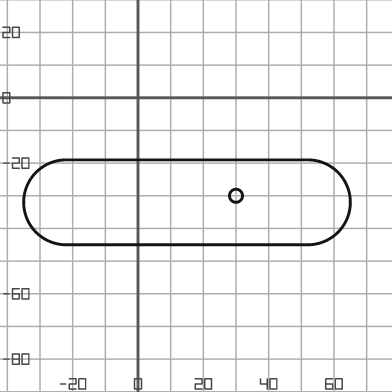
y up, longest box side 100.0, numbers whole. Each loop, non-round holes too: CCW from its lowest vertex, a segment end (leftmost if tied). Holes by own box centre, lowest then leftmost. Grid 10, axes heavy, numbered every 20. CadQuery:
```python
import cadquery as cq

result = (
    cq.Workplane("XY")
    .moveTo(-22.0, -45.0)
    .lineTo(52.0, -45.0)
    .threePointArc((65.0, -32.0), (52.0, -19.0))
    .lineTo(-22.0, -19.0)
    .threePointArc((-35.0, -32.0), (-22.0, -45.0))
    .close()
    .moveTo(30.0, -30.0)
    .circle(2.0)
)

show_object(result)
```